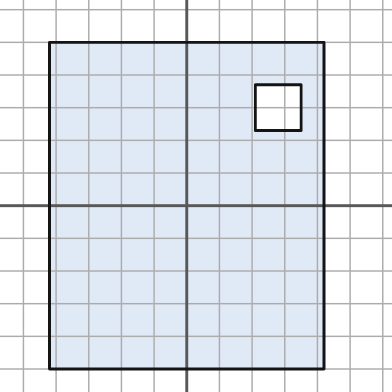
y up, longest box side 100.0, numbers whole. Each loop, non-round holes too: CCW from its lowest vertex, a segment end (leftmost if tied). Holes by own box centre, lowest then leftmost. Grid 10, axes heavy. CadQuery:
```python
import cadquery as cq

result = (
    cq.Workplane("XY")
    .moveTo(-42.0, -50.0)
    .lineTo(42.0, -50.0)
    .lineTo(42.0, 50.0)
    .lineTo(-42.0, 50.0)
    .close()
    .moveTo(21.0, 23.0)
    .lineTo(35.0, 23.0)
    .lineTo(35.0, 37.0)
    .lineTo(21.0, 37.0)
    .close()
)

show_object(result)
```